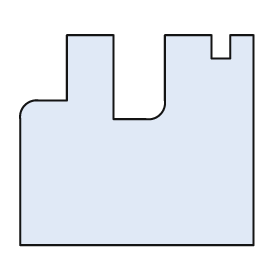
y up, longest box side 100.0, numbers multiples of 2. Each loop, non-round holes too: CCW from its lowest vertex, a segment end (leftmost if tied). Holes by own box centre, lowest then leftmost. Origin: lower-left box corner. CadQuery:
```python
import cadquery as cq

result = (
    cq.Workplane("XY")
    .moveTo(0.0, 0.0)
    .lineTo(100.0, 0.0)
    .lineTo(100.0, 90.0)
    .lineTo(90.0, 90.0)
    .lineTo(90.0, 80.0)
    .lineTo(82.0, 80.0)
    .lineTo(82.0, 90.0)
    .lineTo(62.0, 90.0)
    .lineTo(62.0, 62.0)
    .threePointArc((60.0, 56.0), (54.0, 54.0))
    .lineTo(40.0, 54.0)
    .lineTo(40.0, 90.0)
    .lineTo(20.0, 90.0)
    .lineTo(20.0, 62.0)
    .lineTo(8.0, 62.0)
    .threePointArc((2.0, 60.0), (0.0, 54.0))
    .close()
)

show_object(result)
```